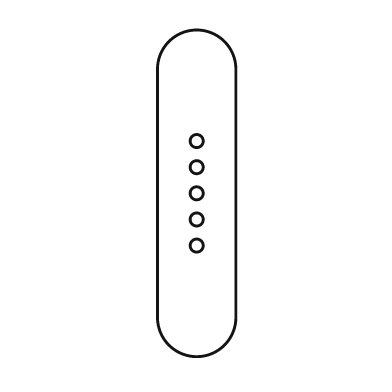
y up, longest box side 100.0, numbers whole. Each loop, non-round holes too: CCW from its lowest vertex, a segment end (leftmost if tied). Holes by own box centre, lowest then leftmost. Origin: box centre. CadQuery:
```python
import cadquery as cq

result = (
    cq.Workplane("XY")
    .moveTo(-12.0, -38.0)
    .threePointArc((0.0, -50.0), (12.0, -38.0))
    .lineTo(12.0, 38.0)
    .threePointArc((0.0, 50.0), (-12.0, 38.0))
    .close()
    .moveTo(0.0, -16.0)
    .circle(2.0)
    .moveTo(0.0, -8.0)
    .circle(2.0)
    .moveTo(0.0, 0.0)
    .circle(2.0)
    .moveTo(0.0, 8.0)
    .circle(2.0)
    .moveTo(0.0, 16.0)
    .circle(2.0)
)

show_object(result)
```